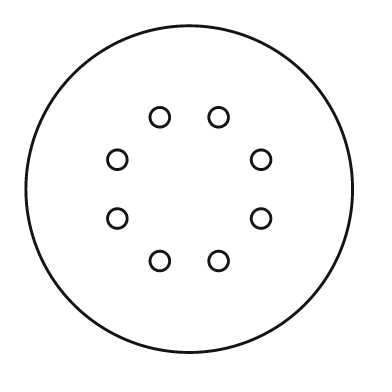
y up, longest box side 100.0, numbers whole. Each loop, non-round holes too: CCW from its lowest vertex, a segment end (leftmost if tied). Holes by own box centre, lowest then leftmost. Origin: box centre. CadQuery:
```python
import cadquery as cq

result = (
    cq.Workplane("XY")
    .moveTo(0.0, 0.0)
    .circle(50.0)
    .moveTo(-9.0, -22.0)
    .circle(3.0)
    .moveTo(9.0, -22.0)
    .circle(3.0)
    .moveTo(-22.0, -9.0)
    .circle(3.0)
    .moveTo(22.0, -9.0)
    .circle(3.0)
    .moveTo(-22.0, 9.0)
    .circle(3.0)
    .moveTo(22.0, 9.0)
    .circle(3.0)
    .moveTo(-9.0, 22.0)
    .circle(3.0)
    .moveTo(9.0, 22.0)
    .circle(3.0)
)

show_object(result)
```